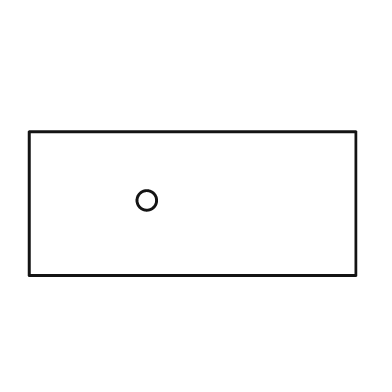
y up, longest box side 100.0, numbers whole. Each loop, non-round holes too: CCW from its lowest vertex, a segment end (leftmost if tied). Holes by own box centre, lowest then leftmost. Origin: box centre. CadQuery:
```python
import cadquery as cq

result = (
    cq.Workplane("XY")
    .moveTo(-50.0, -22.0)
    .lineTo(50.0, -22.0)
    .lineTo(50.0, 22.0)
    .lineTo(-50.0, 22.0)
    .close()
    .moveTo(-14.0, 1.0)
    .circle(3.0)
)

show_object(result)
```